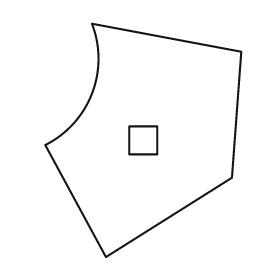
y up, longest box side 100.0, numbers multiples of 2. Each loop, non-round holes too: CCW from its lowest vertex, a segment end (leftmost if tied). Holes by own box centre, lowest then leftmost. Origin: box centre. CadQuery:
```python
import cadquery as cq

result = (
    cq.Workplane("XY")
    .moveTo(-16.0, -50.0)
    .lineTo(38.0, -16.0)
    .lineTo(42.0, 38.0)
    .lineTo(-22.0, 50.0)
    .threePointArc((-22.0, 20.0), (-42.0, -2.0))
    .close()
    .moveTo(-6.0, -6.0)
    .lineTo(6.0, -6.0)
    .lineTo(6.0, 6.0)
    .lineTo(-6.0, 6.0)
    .close()
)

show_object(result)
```